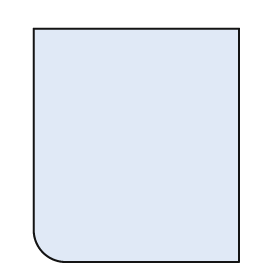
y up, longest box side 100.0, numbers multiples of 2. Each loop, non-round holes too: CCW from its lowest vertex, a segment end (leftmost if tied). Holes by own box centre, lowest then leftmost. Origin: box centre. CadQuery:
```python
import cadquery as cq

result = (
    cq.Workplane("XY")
    .moveTo(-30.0, -50.0)
    .lineTo(44.0, -50.0)
    .lineTo(44.0, 50.0)
    .lineTo(-44.0, 50.0)
    .lineTo(-44.0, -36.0)
    .threePointArc((-40.0, -46.0), (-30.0, -50.0))
    .close()
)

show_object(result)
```